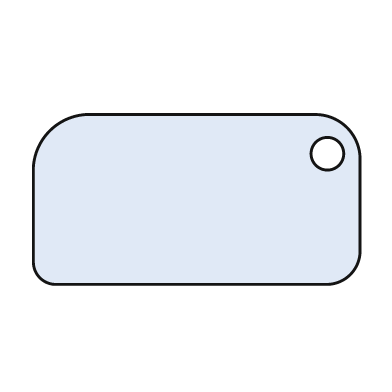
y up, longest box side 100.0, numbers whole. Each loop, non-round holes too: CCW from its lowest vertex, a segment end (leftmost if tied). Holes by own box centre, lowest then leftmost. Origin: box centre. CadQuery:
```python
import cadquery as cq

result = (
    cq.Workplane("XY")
    .moveTo(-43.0, -26.0)
    .lineTo(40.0, -26.0)
    .threePointArc((47.0, -23.0), (50.0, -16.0))
    .lineTo(50.0, 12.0)
    .threePointArc((46.0, 22.0), (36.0, 26.0))
    .lineTo(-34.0, 26.0)
    .threePointArc((-45.0, 21.0), (-50.0, 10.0))
    .lineTo(-50.0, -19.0)
    .threePointArc((-48.0, -24.0), (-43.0, -26.0))
    .close()
    .moveTo(40.0, 14.0)
    .circle(5.0)
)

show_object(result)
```